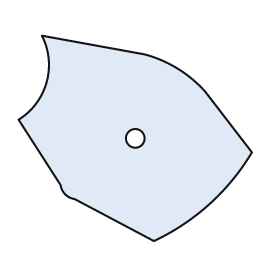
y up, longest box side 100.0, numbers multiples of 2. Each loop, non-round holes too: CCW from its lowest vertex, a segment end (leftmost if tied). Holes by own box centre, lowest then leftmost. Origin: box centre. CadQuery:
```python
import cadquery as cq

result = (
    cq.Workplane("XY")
    .moveTo(8.0, -44.0)
    .threePointArc((32.0, -28.0), (50.0, -6.0))
    .lineTo(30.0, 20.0)
    .threePointArc((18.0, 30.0), (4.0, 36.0))
    .lineTo(-40.0, 44.0)
    .threePointArc((-38.0, 24.0), (-50.0, 8.0))
    .lineTo(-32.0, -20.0)
    .threePointArc((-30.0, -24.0), (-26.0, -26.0))
    .close()
    .moveTo(0.0, 0.0)
    .circle(4.0)
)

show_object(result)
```